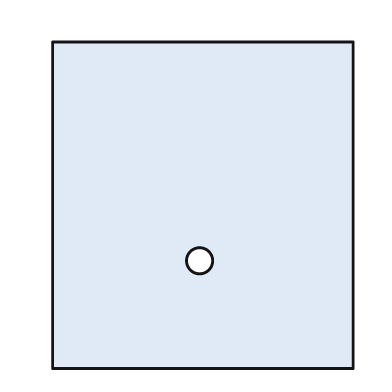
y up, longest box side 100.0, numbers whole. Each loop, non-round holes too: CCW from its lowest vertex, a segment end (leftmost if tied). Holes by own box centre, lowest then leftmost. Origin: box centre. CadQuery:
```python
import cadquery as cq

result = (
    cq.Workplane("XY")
    .moveTo(-46.0, -50.0)
    .lineTo(46.0, -50.0)
    .lineTo(46.0, 50.0)
    .lineTo(-46.0, 50.0)
    .close()
    .moveTo(-1.0, -17.0)
    .circle(4.0)
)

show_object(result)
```